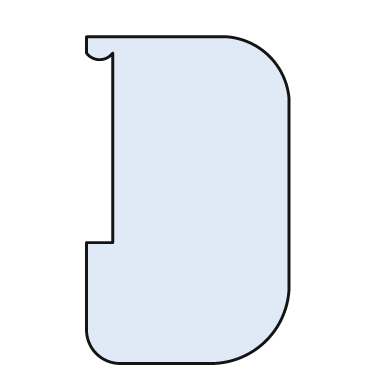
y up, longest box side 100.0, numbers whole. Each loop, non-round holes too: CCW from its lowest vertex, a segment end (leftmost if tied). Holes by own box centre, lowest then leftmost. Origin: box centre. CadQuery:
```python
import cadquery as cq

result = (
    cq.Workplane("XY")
    .moveTo(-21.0, -50.0)
    .lineTo(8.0, -50.0)
    .threePointArc((24.0, -43.0), (31.0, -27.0))
    .lineTo(31.0, 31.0)
    .threePointArc((25.0, 44.0), (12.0, 50.0))
    .lineTo(-31.0, 50.0)
    .lineTo(-31.0, 45.0)
    .threePointArc((-27.0, 43.0), (-23.0, 45.0))
    .lineTo(-23.0, -13.0)
    .lineTo(-31.0, -13.0)
    .lineTo(-31.0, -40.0)
    .threePointArc((-28.0, -47.0), (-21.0, -50.0))
    .close()
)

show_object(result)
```